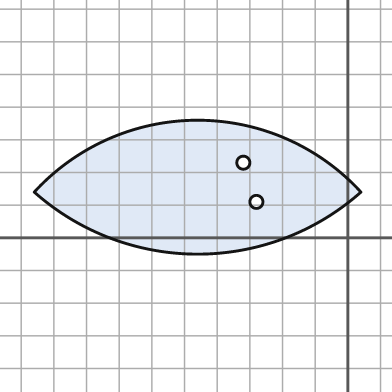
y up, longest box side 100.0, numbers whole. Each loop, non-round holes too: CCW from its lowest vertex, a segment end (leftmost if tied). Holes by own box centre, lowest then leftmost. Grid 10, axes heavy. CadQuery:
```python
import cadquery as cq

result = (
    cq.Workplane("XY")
    .moveTo(-96.0, 14.0)
    .threePointArc((-46.0, -5.0), (4.0, 14.0))
    .threePointArc((-46.0, 36.0), (-96.0, 14.0))
    .close()
    .moveTo(-28.0, 11.0)
    .circle(2.0)
    .moveTo(-32.0, 23.0)
    .circle(2.0)
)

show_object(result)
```